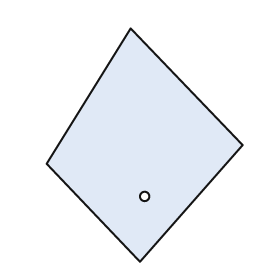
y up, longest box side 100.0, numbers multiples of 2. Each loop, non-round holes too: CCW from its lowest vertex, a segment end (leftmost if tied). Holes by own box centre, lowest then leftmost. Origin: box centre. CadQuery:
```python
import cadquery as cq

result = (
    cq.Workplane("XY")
    .moveTo(-2.0, -50.0)
    .lineTo(42.0, 0.0)
    .lineTo(-6.0, 50.0)
    .lineTo(-42.0, -8.0)
    .close()
    .moveTo(0.0, -22.0)
    .circle(2.0)
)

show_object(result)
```